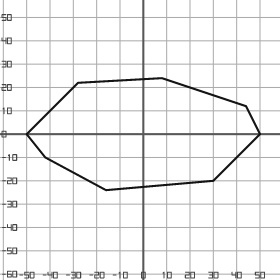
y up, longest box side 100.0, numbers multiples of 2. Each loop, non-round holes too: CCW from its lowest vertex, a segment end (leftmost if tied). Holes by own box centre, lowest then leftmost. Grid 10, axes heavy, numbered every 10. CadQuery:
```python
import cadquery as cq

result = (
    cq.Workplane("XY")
    .moveTo(-16.0, -24.0)
    .lineTo(30.0, -20.0)
    .lineTo(50.0, 0.0)
    .lineTo(44.0, 12.0)
    .lineTo(8.0, 24.0)
    .lineTo(-28.0, 22.0)
    .lineTo(-50.0, 0.0)
    .lineTo(-42.0, -10.0)
    .close()
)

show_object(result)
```